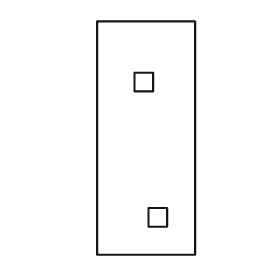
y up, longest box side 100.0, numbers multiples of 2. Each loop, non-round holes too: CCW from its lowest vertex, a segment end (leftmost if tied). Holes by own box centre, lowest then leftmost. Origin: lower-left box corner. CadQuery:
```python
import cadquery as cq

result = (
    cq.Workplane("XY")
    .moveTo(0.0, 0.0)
    .lineTo(42.0, 0.0)
    .lineTo(42.0, 100.0)
    .lineTo(0.0, 100.0)
    .close()
    .moveTo(22.0, 12.0)
    .lineTo(30.0, 12.0)
    .lineTo(30.0, 20.0)
    .lineTo(22.0, 20.0)
    .close()
    .moveTo(16.0, 70.0)
    .lineTo(24.0, 70.0)
    .lineTo(24.0, 78.0)
    .lineTo(16.0, 78.0)
    .close()
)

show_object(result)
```